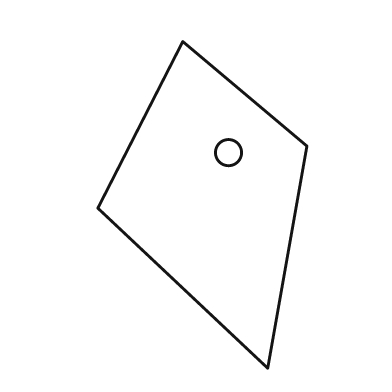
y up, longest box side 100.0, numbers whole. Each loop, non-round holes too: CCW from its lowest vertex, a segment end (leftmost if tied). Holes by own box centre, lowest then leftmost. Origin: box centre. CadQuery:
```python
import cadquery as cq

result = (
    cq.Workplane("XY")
    .moveTo(20.0, -50.0)
    .lineTo(32.0, 18.0)
    .lineTo(-6.0, 50.0)
    .lineTo(-32.0, -1.0)
    .close()
    .moveTo(8.0, 16.0)
    .circle(4.0)
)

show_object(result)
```